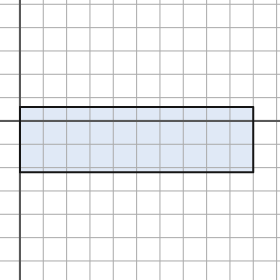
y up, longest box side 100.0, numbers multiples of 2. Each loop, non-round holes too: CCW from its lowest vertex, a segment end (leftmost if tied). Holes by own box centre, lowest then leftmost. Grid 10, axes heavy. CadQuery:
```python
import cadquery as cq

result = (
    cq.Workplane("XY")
    .moveTo(0.0, -22.0)
    .lineTo(100.0, -22.0)
    .lineTo(100.0, 6.0)
    .lineTo(0.0, 6.0)
    .close()
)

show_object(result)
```